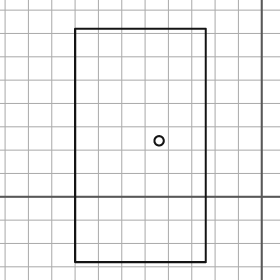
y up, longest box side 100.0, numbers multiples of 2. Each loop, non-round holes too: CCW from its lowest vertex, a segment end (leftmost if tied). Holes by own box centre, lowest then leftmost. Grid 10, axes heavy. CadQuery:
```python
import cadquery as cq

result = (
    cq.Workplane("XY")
    .moveTo(-80.0, -28.0)
    .lineTo(-24.0, -28.0)
    .lineTo(-24.0, 72.0)
    .lineTo(-80.0, 72.0)
    .close()
    .moveTo(-44.0, 24.0)
    .circle(2.0)
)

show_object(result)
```